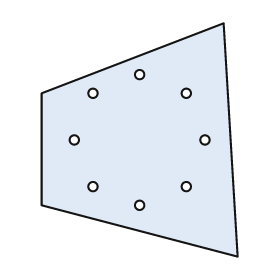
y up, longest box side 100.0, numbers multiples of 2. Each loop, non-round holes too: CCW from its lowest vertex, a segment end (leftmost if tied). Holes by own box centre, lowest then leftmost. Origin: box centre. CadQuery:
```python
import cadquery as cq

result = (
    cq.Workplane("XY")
    .moveTo(42.0, -50.0)
    .lineTo(36.0, 50.0)
    .lineTo(-42.0, 20.0)
    .lineTo(-42.0, -28.0)
    .close()
    .moveTo(0.0, -28.0)
    .circle(2.0)
    .moveTo(-20.0, -20.0)
    .circle(2.0)
    .moveTo(20.0, -20.0)
    .circle(2.0)
    .moveTo(-28.0, 0.0)
    .circle(2.0)
    .moveTo(28.0, 0.0)
    .circle(2.0)
    .moveTo(-20.0, 20.0)
    .circle(2.0)
    .moveTo(20.0, 20.0)
    .circle(2.0)
    .moveTo(0.0, 28.0)
    .circle(2.0)
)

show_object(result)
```